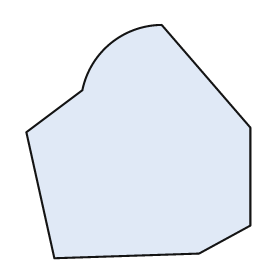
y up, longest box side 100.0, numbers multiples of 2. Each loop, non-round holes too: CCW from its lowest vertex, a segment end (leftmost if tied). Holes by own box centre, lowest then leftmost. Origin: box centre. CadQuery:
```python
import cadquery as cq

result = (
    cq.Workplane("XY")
    .moveTo(-36.0, -50.0)
    .lineTo(26.0, -48.0)
    .lineTo(48.0, -36.0)
    .lineTo(48.0, 6.0)
    .lineTo(10.0, 50.0)
    .threePointArc((-12.0, 42.0), (-24.0, 22.0))
    .lineTo(-48.0, 4.0)
    .close()
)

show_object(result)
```